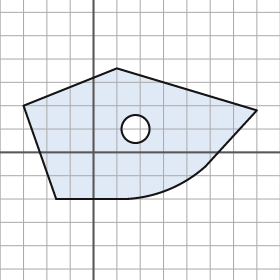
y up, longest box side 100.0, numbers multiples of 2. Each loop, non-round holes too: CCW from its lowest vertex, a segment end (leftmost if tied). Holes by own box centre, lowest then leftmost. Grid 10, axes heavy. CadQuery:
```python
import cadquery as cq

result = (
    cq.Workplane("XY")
    .moveTo(-16.0, -20.0)
    .lineTo(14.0, -20.0)
    .threePointArc((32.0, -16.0), (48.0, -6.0))
    .lineTo(70.0, 18.0)
    .lineTo(10.0, 36.0)
    .lineTo(-30.0, 20.0)
    .close()
    .moveTo(18.0, 10.0)
    .circle(6.0)
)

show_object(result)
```